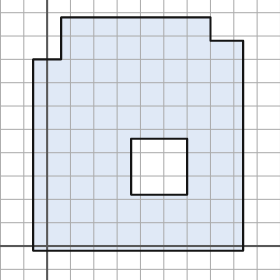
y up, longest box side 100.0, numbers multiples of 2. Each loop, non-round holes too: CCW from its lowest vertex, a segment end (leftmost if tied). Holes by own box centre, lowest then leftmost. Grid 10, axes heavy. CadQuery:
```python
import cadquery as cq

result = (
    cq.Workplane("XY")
    .moveTo(-6.0, -2.0)
    .lineTo(84.0, -2.0)
    .lineTo(84.0, 88.0)
    .lineTo(70.0, 88.0)
    .lineTo(70.0, 98.0)
    .lineTo(6.0, 98.0)
    .lineTo(6.0, 80.0)
    .lineTo(-6.0, 80.0)
    .close()
    .moveTo(36.0, 22.0)
    .lineTo(60.0, 22.0)
    .lineTo(60.0, 46.0)
    .lineTo(36.0, 46.0)
    .close()
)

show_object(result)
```